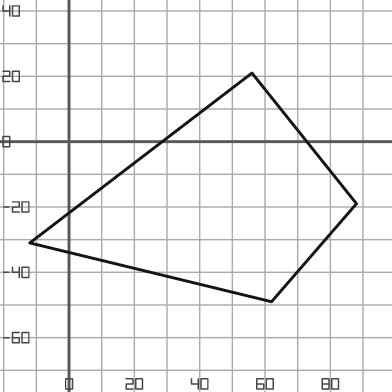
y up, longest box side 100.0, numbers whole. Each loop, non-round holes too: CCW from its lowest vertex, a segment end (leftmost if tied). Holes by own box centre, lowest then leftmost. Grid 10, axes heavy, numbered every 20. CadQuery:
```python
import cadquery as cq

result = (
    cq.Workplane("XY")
    .moveTo(62.0, -49.0)
    .lineTo(88.0, -19.0)
    .lineTo(56.0, 21.0)
    .lineTo(-12.0, -31.0)
    .close()
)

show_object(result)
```